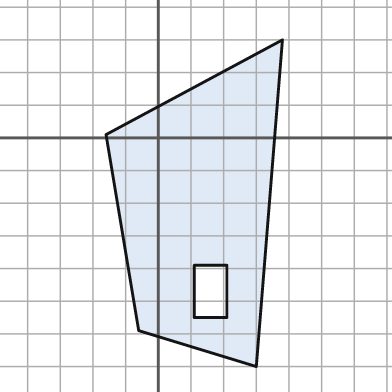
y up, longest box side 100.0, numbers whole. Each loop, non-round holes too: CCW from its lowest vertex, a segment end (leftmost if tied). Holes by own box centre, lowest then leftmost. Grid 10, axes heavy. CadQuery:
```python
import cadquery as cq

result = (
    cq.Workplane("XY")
    .moveTo(30.0, -70.0)
    .lineTo(38.0, 30.0)
    .lineTo(-16.0, 1.0)
    .lineTo(-6.0, -59.0)
    .close()
    .moveTo(11.0, -55.0)
    .lineTo(21.0, -55.0)
    .lineTo(21.0, -39.0)
    .lineTo(11.0, -39.0)
    .close()
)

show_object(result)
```